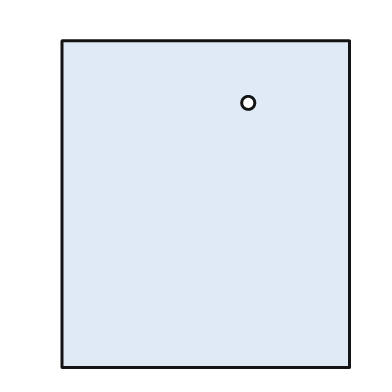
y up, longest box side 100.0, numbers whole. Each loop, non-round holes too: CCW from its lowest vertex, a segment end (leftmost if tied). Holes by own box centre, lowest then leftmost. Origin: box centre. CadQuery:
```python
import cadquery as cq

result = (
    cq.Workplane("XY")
    .moveTo(-44.0, -50.0)
    .lineTo(44.0, -50.0)
    .lineTo(44.0, 50.0)
    .lineTo(-44.0, 50.0)
    .close()
    .moveTo(13.0, 31.0)
    .circle(2.0)
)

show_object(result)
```